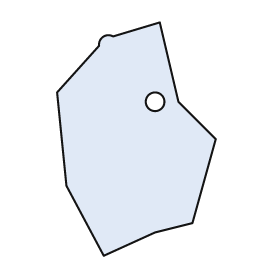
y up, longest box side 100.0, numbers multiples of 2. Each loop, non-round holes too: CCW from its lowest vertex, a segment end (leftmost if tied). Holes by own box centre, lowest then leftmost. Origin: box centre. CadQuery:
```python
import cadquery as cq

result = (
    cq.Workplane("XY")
    .moveTo(-14.0, -50.0)
    .lineTo(8.0, -40.0)
    .lineTo(24.0, -36.0)
    .lineTo(34.0, 0.0)
    .lineTo(18.0, 16.0)
    .lineTo(10.0, 50.0)
    .lineTo(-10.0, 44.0)
    .threePointArc((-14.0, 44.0), (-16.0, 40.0))
    .lineTo(-34.0, 20.0)
    .lineTo(-30.0, -20.0)
    .close()
    .moveTo(8.0, 16.0)
    .circle(4.0)
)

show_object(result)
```